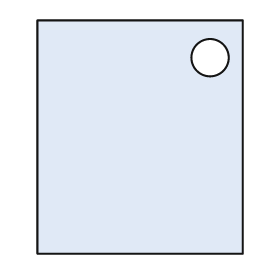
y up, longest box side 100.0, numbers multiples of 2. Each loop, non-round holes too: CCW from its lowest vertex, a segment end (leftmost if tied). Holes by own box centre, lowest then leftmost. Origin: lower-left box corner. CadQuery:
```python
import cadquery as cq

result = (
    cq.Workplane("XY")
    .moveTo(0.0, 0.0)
    .lineTo(88.0, 0.0)
    .lineTo(88.0, 100.0)
    .lineTo(0.0, 100.0)
    .close()
    .moveTo(74.0, 84.0)
    .circle(8.0)
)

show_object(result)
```